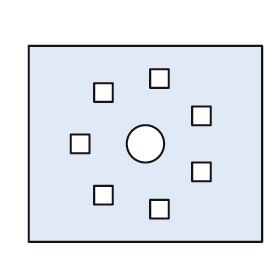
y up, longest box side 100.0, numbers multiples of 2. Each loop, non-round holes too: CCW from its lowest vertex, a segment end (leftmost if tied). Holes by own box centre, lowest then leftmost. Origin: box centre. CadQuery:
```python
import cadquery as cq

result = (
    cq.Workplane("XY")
    .moveTo(-50.0, -42.0)
    .lineTo(50.0, -42.0)
    .lineTo(50.0, 42.0)
    .lineTo(-50.0, 42.0)
    .close()
    .moveTo(2.0, -32.0)
    .lineTo(10.0, -32.0)
    .lineTo(10.0, -24.0)
    .lineTo(2.0, -24.0)
    .close()
    .moveTo(-22.0, -26.0)
    .lineTo(-14.0, -26.0)
    .lineTo(-14.0, -18.0)
    .lineTo(-22.0, -18.0)
    .close()
    .moveTo(20.0, -16.0)
    .lineTo(28.0, -16.0)
    .lineTo(28.0, -8.0)
    .lineTo(20.0, -8.0)
    .close()
    .moveTo(-32.0, -4.0)
    .lineTo(-24.0, -4.0)
    .lineTo(-24.0, 4.0)
    .lineTo(-32.0, 4.0)
    .close()
    .moveTo(0.0, 0.0)
    .circle(8.0)
    .moveTo(20.0, 8.0)
    .lineTo(28.0, 8.0)
    .lineTo(28.0, 16.0)
    .lineTo(20.0, 16.0)
    .close()
    .moveTo(-22.0, 18.0)
    .lineTo(-14.0, 18.0)
    .lineTo(-14.0, 26.0)
    .lineTo(-22.0, 26.0)
    .close()
    .moveTo(2.0, 24.0)
    .lineTo(10.0, 24.0)
    .lineTo(10.0, 32.0)
    .lineTo(2.0, 32.0)
    .close()
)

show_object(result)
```